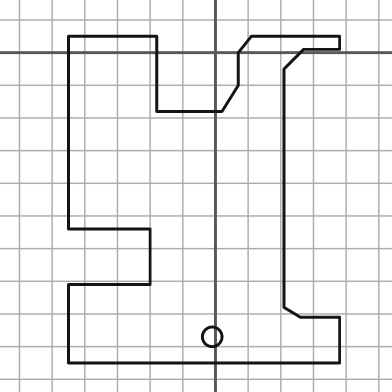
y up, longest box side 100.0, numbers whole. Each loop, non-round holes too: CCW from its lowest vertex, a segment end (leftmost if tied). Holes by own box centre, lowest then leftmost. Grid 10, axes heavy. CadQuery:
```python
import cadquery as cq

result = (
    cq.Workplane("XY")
    .moveTo(-45.0, -95.0)
    .lineTo(38.0, -95.0)
    .lineTo(38.0, -81.0)
    .lineTo(26.0, -81.0)
    .lineTo(21.0, -78.0)
    .lineTo(21.0, -5.0)
    .lineTo(27.0, 1.0)
    .lineTo(38.0, 1.0)
    .lineTo(38.0, 5.0)
    .lineTo(11.0, 5.0)
    .lineTo(7.0, 0.0)
    .lineTo(7.0, -10.0)
    .lineTo(2.0, -18.0)
    .lineTo(-18.0, -18.0)
    .lineTo(-18.0, 5.0)
    .lineTo(-45.0, 5.0)
    .lineTo(-45.0, -54.0)
    .lineTo(-20.0, -54.0)
    .lineTo(-20.0, -71.0)
    .lineTo(-45.0, -71.0)
    .close()
    .moveTo(-1.0, -87.0)
    .circle(3.0)
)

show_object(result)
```